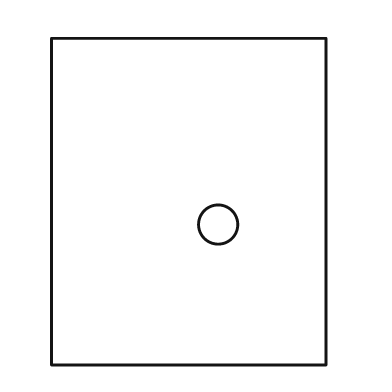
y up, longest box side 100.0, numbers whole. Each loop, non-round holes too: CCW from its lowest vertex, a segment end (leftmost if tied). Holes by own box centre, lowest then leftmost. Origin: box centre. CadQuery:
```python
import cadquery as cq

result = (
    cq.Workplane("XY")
    .moveTo(-42.0, -50.0)
    .lineTo(42.0, -50.0)
    .lineTo(42.0, 50.0)
    .lineTo(-42.0, 50.0)
    .close()
    .moveTo(9.0, -7.0)
    .circle(6.0)
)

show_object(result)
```